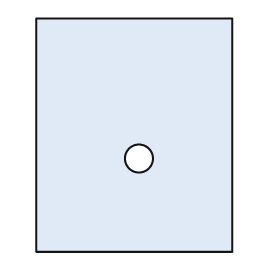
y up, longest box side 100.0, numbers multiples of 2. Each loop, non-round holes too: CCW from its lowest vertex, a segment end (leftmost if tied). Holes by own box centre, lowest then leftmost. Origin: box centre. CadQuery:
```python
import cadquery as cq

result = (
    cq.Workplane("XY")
    .moveTo(-42.0, -50.0)
    .lineTo(42.0, -50.0)
    .lineTo(42.0, 50.0)
    .lineTo(-42.0, 50.0)
    .close()
    .moveTo(2.0, -10.0)
    .circle(6.0)
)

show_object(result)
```